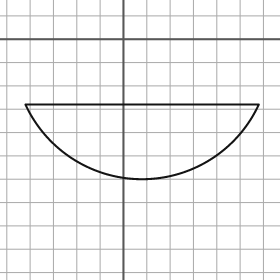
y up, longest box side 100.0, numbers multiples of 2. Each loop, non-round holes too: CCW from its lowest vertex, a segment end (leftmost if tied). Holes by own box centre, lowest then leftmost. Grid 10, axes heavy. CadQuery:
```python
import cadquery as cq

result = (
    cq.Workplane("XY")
    .moveTo(-42.0, -28.0)
    .threePointArc((8.0, -60.0), (58.0, -28.0))
    .close()
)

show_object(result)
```